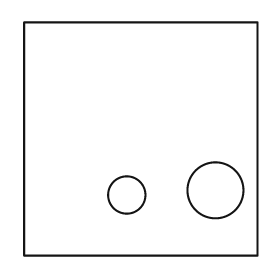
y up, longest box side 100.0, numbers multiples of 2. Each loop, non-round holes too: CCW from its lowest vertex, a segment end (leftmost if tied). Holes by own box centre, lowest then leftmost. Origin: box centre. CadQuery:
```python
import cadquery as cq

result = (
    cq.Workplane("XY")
    .moveTo(-50.0, -50.0)
    .lineTo(50.0, -50.0)
    .lineTo(50.0, 50.0)
    .lineTo(-50.0, 50.0)
    .close()
    .moveTo(-6.0, -24.0)
    .circle(8.0)
    .moveTo(32.0, -22.0)
    .circle(12.0)
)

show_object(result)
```